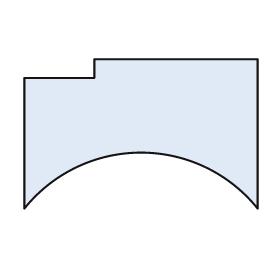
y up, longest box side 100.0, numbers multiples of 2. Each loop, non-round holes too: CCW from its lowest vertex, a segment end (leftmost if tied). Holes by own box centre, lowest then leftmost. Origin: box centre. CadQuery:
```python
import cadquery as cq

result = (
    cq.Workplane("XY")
    .moveTo(-50.0, -32.0)
    .threePointArc((0.0, -8.0), (50.0, -32.0))
    .lineTo(50.0, 32.0)
    .lineTo(-20.0, 32.0)
    .lineTo(-20.0, 24.0)
    .lineTo(-50.0, 24.0)
    .close()
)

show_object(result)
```